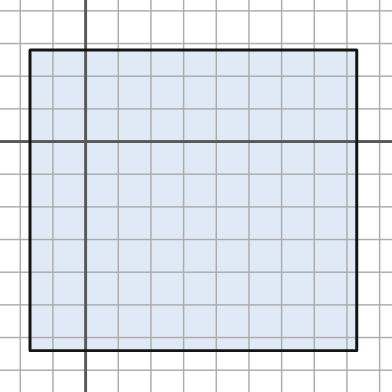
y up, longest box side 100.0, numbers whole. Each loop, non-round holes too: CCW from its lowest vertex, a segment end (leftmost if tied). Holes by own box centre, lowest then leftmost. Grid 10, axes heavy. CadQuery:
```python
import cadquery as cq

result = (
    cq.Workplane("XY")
    .moveTo(-17.0, -64.0)
    .lineTo(83.0, -64.0)
    .lineTo(83.0, 28.0)
    .lineTo(-17.0, 28.0)
    .close()
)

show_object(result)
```